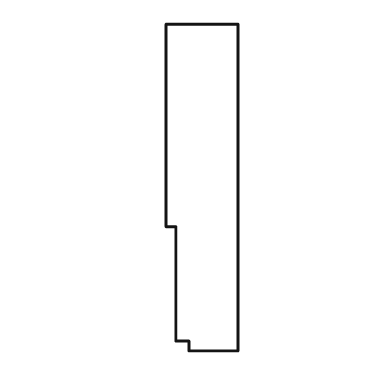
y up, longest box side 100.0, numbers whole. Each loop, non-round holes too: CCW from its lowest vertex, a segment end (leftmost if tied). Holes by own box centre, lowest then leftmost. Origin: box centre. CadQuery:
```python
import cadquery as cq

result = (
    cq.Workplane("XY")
    .moveTo(-4.0, -50.0)
    .lineTo(11.0, -50.0)
    .lineTo(11.0, 50.0)
    .lineTo(-11.0, 50.0)
    .lineTo(-11.0, -12.0)
    .lineTo(-8.0, -12.0)
    .lineTo(-8.0, -47.0)
    .lineTo(-4.0, -47.0)
    .close()
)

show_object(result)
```